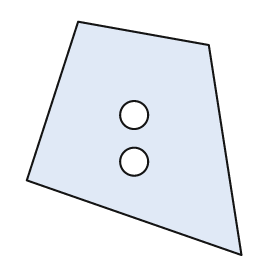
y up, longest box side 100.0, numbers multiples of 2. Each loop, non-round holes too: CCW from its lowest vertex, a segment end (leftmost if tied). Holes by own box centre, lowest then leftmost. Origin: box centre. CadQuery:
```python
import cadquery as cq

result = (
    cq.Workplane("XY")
    .moveTo(46.0, -50.0)
    .lineTo(32.0, 40.0)
    .lineTo(-24.0, 50.0)
    .lineTo(-46.0, -18.0)
    .close()
    .moveTo(0.0, -10.0)
    .circle(6.0)
    .moveTo(0.0, 10.0)
    .circle(6.0)
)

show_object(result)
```